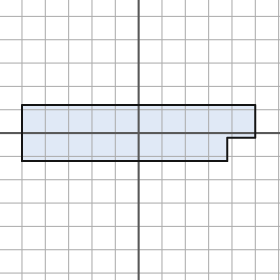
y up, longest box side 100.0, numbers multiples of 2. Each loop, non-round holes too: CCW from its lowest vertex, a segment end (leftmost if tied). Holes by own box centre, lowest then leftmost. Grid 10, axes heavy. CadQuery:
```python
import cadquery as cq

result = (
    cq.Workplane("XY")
    .moveTo(-50.0, -12.0)
    .lineTo(38.0, -12.0)
    .lineTo(38.0, -2.0)
    .lineTo(50.0, -2.0)
    .lineTo(50.0, 12.0)
    .lineTo(-50.0, 12.0)
    .close()
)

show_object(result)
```